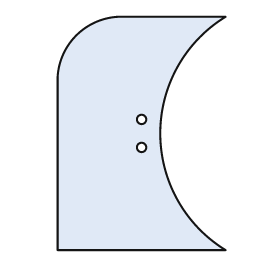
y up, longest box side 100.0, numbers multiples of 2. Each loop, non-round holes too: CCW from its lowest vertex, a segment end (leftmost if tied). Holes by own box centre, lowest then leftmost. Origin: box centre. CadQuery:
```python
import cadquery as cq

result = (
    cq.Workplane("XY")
    .moveTo(-36.0, -50.0)
    .lineTo(36.0, -50.0)
    .threePointArc((8.0, 0.0), (36.0, 50.0))
    .lineTo(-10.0, 50.0)
    .threePointArc((-28.0, 42.0), (-36.0, 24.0))
    .close()
    .moveTo(0.0, -6.0)
    .circle(2.0)
    .moveTo(0.0, 6.0)
    .circle(2.0)
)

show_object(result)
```